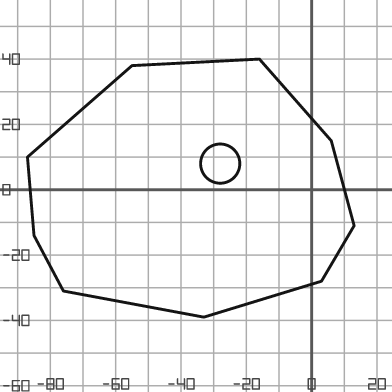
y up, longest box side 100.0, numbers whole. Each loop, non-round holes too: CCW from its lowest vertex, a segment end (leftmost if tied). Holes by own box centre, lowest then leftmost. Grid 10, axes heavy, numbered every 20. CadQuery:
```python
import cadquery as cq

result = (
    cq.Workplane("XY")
    .moveTo(-33.0, -39.0)
    .lineTo(3.0, -28.0)
    .lineTo(13.0, -11.0)
    .lineTo(6.0, 15.0)
    .lineTo(-16.0, 40.0)
    .lineTo(-55.0, 38.0)
    .lineTo(-87.0, 10.0)
    .lineTo(-85.0, -14.0)
    .lineTo(-76.0, -31.0)
    .close()
    .moveTo(-28.0, 8.0)
    .circle(6.0)
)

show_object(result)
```